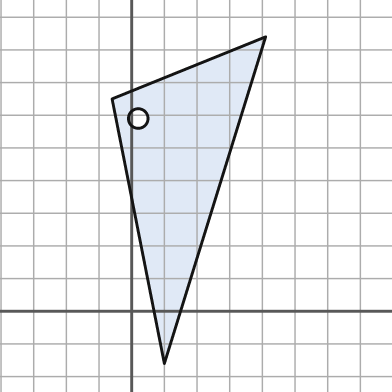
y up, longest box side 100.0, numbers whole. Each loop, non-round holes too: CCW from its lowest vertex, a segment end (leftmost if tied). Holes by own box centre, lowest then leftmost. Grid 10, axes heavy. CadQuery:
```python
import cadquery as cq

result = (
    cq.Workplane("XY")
    .moveTo(10.0, -16.0)
    .lineTo(41.0, 84.0)
    .lineTo(-6.0, 65.0)
    .close()
    .moveTo(2.0, 59.0)
    .circle(3.0)
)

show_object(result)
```